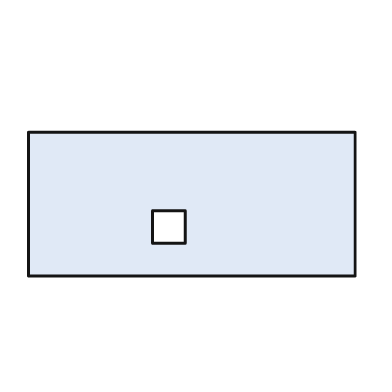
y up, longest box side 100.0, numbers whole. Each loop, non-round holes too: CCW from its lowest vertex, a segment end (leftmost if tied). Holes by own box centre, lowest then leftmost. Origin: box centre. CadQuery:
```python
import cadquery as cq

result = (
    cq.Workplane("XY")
    .moveTo(-50.0, -22.0)
    .lineTo(50.0, -22.0)
    .lineTo(50.0, 22.0)
    .lineTo(-50.0, 22.0)
    .close()
    .moveTo(-12.0, -12.0)
    .lineTo(-2.0, -12.0)
    .lineTo(-2.0, -2.0)
    .lineTo(-12.0, -2.0)
    .close()
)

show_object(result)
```